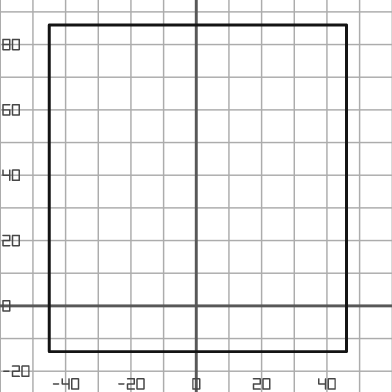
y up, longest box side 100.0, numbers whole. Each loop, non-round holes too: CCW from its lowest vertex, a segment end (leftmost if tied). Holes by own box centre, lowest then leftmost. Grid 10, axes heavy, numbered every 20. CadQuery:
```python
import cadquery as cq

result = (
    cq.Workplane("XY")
    .moveTo(-45.0, -14.0)
    .lineTo(46.0, -14.0)
    .lineTo(46.0, 86.0)
    .lineTo(-45.0, 86.0)
    .close()
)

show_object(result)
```